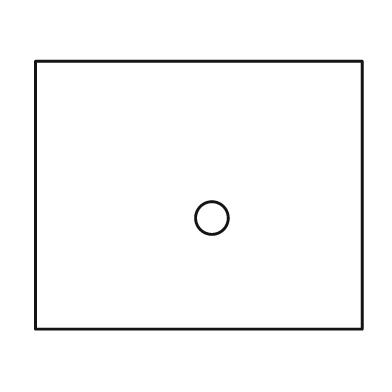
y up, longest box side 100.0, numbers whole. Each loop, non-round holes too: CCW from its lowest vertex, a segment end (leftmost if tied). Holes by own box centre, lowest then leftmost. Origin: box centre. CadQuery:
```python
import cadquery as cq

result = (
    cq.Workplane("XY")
    .moveTo(-50.0, -41.0)
    .lineTo(50.0, -41.0)
    .lineTo(50.0, 41.0)
    .lineTo(-50.0, 41.0)
    .close()
    .moveTo(4.0, -7.0)
    .circle(5.0)
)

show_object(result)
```